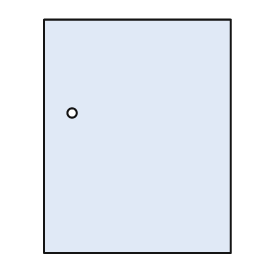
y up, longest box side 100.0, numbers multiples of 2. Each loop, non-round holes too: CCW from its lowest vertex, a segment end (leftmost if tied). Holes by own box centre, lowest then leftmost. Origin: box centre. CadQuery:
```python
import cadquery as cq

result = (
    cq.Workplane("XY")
    .moveTo(-40.0, -50.0)
    .lineTo(40.0, -50.0)
    .lineTo(40.0, 50.0)
    .lineTo(-40.0, 50.0)
    .close()
    .moveTo(-28.0, 10.0)
    .circle(2.0)
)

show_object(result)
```